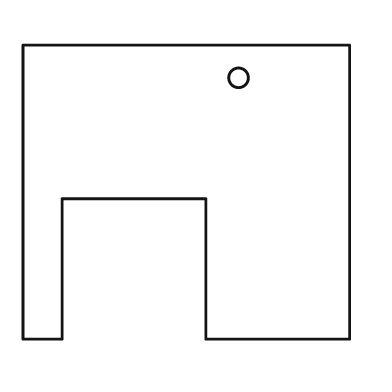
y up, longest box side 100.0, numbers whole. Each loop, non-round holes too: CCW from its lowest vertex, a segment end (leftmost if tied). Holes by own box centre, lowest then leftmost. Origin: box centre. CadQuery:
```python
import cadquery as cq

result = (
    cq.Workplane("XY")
    .moveTo(-50.0, -45.0)
    .lineTo(-38.0, -45.0)
    .lineTo(-38.0, -2.0)
    .lineTo(6.0, -2.0)
    .lineTo(6.0, -45.0)
    .lineTo(50.0, -45.0)
    .lineTo(50.0, 45.0)
    .lineTo(-50.0, 45.0)
    .close()
    .moveTo(16.0, 35.0)
    .circle(3.0)
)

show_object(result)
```